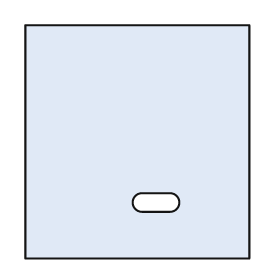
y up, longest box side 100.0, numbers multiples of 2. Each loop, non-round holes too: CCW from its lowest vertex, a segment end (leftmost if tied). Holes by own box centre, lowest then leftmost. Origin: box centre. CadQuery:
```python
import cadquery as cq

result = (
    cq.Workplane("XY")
    .moveTo(-48.0, -50.0)
    .lineTo(48.0, -50.0)
    .lineTo(48.0, 50.0)
    .lineTo(-48.0, 50.0)
    .close()
    .moveTo(2.0, -30.0)
    .lineTo(14.0, -30.0)
    .threePointArc((18.0, -26.0), (14.0, -22.0))
    .lineTo(2.0, -22.0)
    .threePointArc((-2.0, -26.0), (2.0, -30.0))
    .close()
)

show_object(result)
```